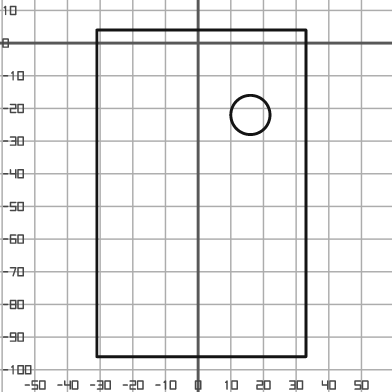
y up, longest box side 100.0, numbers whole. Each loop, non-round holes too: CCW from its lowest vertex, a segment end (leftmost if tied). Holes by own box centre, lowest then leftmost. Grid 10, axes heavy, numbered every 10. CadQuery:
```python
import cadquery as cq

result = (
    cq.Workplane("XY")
    .moveTo(-31.0, -96.0)
    .lineTo(33.0, -96.0)
    .lineTo(33.0, 4.0)
    .lineTo(-31.0, 4.0)
    .close()
    .moveTo(16.0, -22.0)
    .circle(6.0)
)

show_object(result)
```